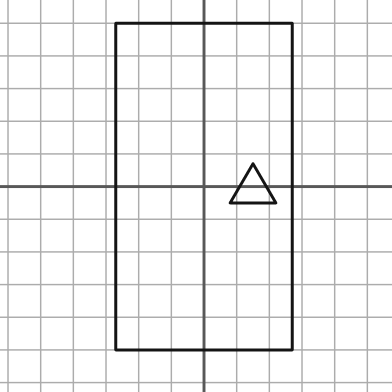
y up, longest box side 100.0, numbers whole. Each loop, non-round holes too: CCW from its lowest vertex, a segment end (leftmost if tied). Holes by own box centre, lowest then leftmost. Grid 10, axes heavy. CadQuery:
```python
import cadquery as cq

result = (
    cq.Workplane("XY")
    .moveTo(-27.0, -50.0)
    .lineTo(27.0, -50.0)
    .lineTo(27.0, 50.0)
    .lineTo(-27.0, 50.0)
    .close()
    .moveTo(8.0, -5.0)
    .lineTo(22.0, -5.0)
    .lineTo(15.0, 7.0)
    .close()
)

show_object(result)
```